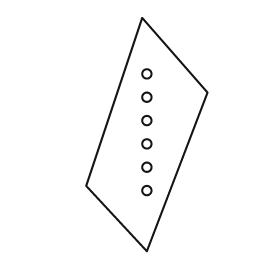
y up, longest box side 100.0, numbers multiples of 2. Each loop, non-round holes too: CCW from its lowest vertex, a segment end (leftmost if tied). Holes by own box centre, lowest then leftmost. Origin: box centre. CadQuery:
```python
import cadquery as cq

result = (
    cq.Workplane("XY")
    .moveTo(0.0, -50.0)
    .lineTo(26.0, 18.0)
    .lineTo(-2.0, 50.0)
    .lineTo(-26.0, -22.0)
    .close()
    .moveTo(0.0, -24.0)
    .circle(2.0)
    .moveTo(0.0, -14.0)
    .circle(2.0)
    .moveTo(0.0, -4.0)
    .circle(2.0)
    .moveTo(0.0, 6.0)
    .circle(2.0)
    .moveTo(0.0, 16.0)
    .circle(2.0)
    .moveTo(0.0, 26.0)
    .circle(2.0)
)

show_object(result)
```